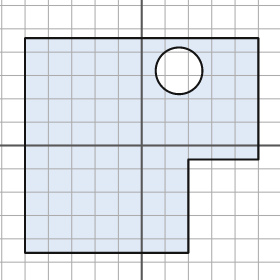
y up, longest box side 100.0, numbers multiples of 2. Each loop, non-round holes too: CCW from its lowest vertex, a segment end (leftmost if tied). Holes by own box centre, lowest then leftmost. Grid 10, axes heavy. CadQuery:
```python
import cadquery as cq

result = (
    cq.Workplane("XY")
    .moveTo(-50.0, -46.0)
    .lineTo(20.0, -46.0)
    .lineTo(20.0, -6.0)
    .lineTo(50.0, -6.0)
    .lineTo(50.0, 46.0)
    .lineTo(-50.0, 46.0)
    .close()
    .moveTo(16.0, 32.0)
    .circle(10.0)
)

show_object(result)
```